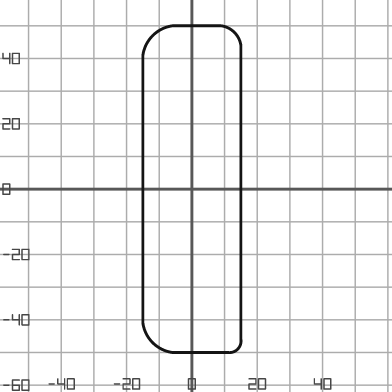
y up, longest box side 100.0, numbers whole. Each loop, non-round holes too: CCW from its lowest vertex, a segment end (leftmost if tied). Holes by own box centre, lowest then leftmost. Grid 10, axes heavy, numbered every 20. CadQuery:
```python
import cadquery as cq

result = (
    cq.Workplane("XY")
    .moveTo(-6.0, -50.0)
    .lineTo(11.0, -50.0)
    .threePointArc((14.0, -49.0), (15.0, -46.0))
    .lineTo(15.0, 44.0)
    .threePointArc((13.0, 48.0), (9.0, 50.0))
    .lineTo(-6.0, 50.0)
    .threePointArc((-12.0, 47.0), (-15.0, 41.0))
    .lineTo(-15.0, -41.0)
    .threePointArc((-12.0, -47.0), (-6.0, -50.0))
    .close()
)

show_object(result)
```